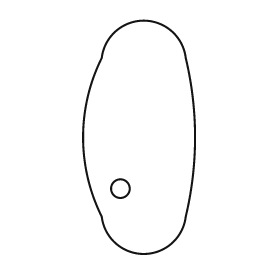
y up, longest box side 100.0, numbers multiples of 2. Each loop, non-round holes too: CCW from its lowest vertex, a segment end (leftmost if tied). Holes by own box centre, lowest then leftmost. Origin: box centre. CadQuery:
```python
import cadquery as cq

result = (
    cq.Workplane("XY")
    .moveTo(-16.0, -34.0)
    .threePointArc((2.0, -50.0), (20.0, -34.0))
    .threePointArc((24.0, 0.0), (20.0, 34.0))
    .threePointArc((2.0, 50.0), (-16.0, 34.0))
    .threePointArc((-24.0, 0.0), (-16.0, -34.0))
    .close()
    .moveTo(-8.0, -22.0)
    .circle(4.0)
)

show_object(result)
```